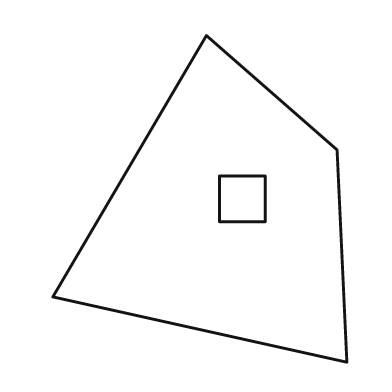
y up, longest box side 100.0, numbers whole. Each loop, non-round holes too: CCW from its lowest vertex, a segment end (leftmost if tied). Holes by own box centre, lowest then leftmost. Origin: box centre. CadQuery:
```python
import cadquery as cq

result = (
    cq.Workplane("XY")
    .moveTo(45.0, -50.0)
    .lineTo(42.0, 15.0)
    .lineTo(2.0, 50.0)
    .lineTo(-45.0, -30.0)
    .close()
    .moveTo(6.0, -7.0)
    .lineTo(20.0, -7.0)
    .lineTo(20.0, 7.0)
    .lineTo(6.0, 7.0)
    .close()
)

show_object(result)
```